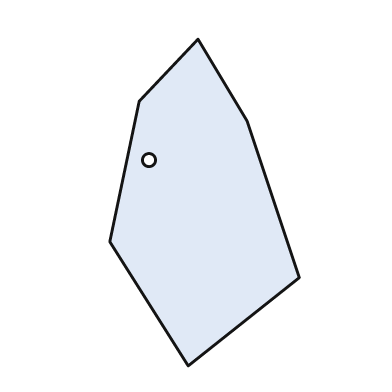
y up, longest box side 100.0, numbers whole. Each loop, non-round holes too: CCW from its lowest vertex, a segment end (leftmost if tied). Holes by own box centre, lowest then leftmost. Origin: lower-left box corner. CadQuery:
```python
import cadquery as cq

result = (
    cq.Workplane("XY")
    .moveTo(24.0, 0.0)
    .lineTo(58.0, 27.0)
    .lineTo(42.0, 75.0)
    .lineTo(27.0, 100.0)
    .lineTo(9.0, 81.0)
    .lineTo(0.0, 38.0)
    .close()
    .moveTo(12.0, 63.0)
    .circle(2.0)
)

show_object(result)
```